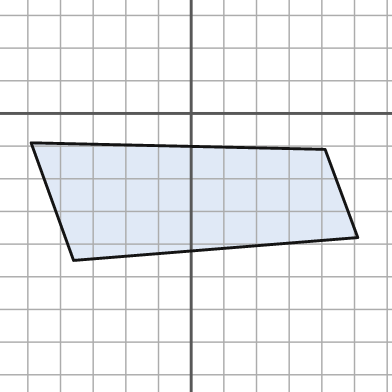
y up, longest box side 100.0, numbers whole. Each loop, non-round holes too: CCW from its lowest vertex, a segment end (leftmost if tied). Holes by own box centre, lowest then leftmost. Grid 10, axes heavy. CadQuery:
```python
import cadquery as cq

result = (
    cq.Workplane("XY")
    .moveTo(-36.0, -45.0)
    .lineTo(51.0, -38.0)
    .lineTo(41.0, -11.0)
    .lineTo(-49.0, -9.0)
    .close()
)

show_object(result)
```